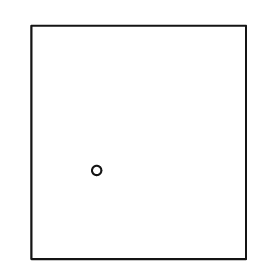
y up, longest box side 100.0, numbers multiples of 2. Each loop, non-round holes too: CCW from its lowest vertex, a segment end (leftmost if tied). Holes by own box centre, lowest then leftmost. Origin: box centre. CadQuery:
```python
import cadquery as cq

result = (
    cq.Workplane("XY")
    .moveTo(-46.0, -50.0)
    .lineTo(46.0, -50.0)
    .lineTo(46.0, 50.0)
    .lineTo(-46.0, 50.0)
    .close()
    .moveTo(-18.0, -12.0)
    .circle(2.0)
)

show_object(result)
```